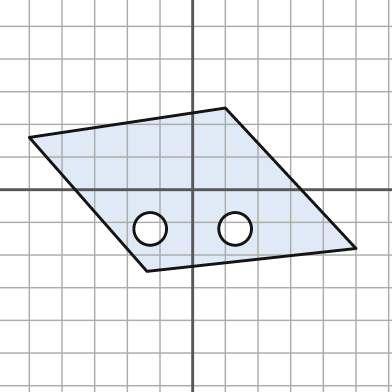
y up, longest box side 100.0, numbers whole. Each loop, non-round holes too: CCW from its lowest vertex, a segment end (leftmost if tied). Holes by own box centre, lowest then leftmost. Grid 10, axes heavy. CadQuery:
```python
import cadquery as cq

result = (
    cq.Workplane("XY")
    .moveTo(-14.0, -25.0)
    .lineTo(50.0, -18.0)
    .lineTo(10.0, 25.0)
    .lineTo(-50.0, 16.0)
    .close()
    .moveTo(-13.0, -12.0)
    .circle(5.0)
    .moveTo(13.0, -12.0)
    .circle(5.0)
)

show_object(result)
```